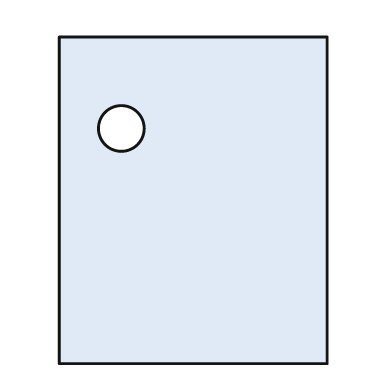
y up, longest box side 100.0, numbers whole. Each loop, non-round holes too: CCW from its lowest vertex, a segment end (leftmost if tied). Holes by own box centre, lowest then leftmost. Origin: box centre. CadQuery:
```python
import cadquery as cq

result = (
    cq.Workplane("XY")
    .moveTo(-41.0, -50.0)
    .lineTo(41.0, -50.0)
    .lineTo(41.0, 50.0)
    .lineTo(-41.0, 50.0)
    .close()
    .moveTo(-22.0, 22.0)
    .circle(7.0)
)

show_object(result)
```